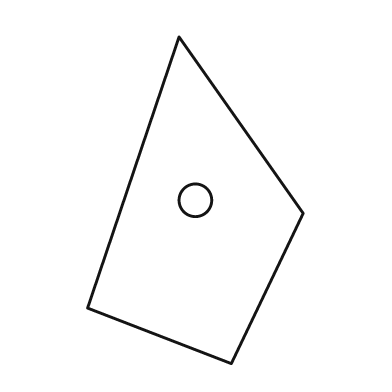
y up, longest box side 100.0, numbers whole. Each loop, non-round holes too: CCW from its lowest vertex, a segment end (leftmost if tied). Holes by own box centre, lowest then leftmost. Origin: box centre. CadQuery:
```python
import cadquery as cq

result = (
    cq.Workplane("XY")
    .moveTo(11.0, -50.0)
    .lineTo(33.0, -4.0)
    .lineTo(-5.0, 50.0)
    .lineTo(-33.0, -33.0)
    .close()
    .moveTo(0.0, 0.0)
    .circle(5.0)
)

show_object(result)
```